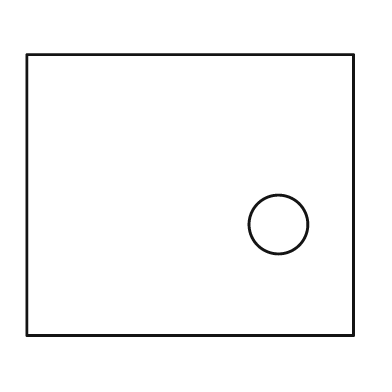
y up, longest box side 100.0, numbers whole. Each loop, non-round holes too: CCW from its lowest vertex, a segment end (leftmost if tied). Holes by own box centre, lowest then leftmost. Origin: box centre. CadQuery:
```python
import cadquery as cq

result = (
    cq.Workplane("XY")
    .moveTo(-50.0, -43.0)
    .lineTo(50.0, -43.0)
    .lineTo(50.0, 43.0)
    .lineTo(-50.0, 43.0)
    .close()
    .moveTo(27.0, -9.0)
    .circle(9.0)
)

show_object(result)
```